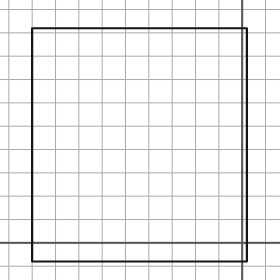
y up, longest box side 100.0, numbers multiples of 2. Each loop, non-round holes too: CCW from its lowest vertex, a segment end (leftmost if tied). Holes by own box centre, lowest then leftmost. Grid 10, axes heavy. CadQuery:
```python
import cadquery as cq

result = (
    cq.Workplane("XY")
    .moveTo(-90.0, -8.0)
    .lineTo(2.0, -8.0)
    .lineTo(2.0, 92.0)
    .lineTo(-90.0, 92.0)
    .close()
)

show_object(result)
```